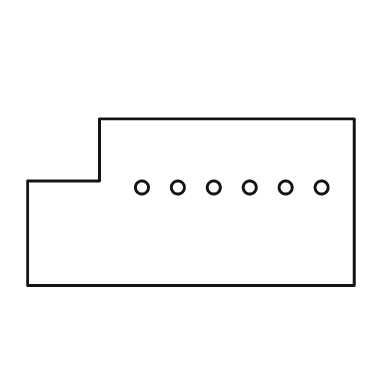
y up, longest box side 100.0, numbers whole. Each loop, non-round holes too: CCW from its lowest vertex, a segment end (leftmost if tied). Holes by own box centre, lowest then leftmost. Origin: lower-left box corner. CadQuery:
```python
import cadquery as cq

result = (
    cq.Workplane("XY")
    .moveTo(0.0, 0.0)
    .lineTo(100.0, 0.0)
    .lineTo(100.0, 51.0)
    .lineTo(22.0, 51.0)
    .lineTo(22.0, 32.0)
    .lineTo(0.0, 32.0)
    .close()
    .moveTo(35.0, 30.0)
    .circle(2.0)
    .moveTo(46.0, 30.0)
    .circle(2.0)
    .moveTo(57.0, 30.0)
    .circle(2.0)
    .moveTo(68.0, 30.0)
    .circle(2.0)
    .moveTo(79.0, 30.0)
    .circle(2.0)
    .moveTo(90.0, 30.0)
    .circle(2.0)
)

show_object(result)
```